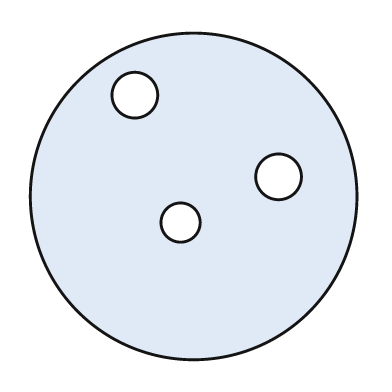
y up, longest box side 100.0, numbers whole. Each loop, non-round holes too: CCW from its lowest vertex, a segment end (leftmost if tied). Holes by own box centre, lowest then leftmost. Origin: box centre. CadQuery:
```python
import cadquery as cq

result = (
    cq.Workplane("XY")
    .moveTo(0.0, 0.0)
    .circle(50.0)
    .moveTo(-4.0, -8.0)
    .circle(6.0)
    .moveTo(26.0, 6.0)
    .circle(7.0)
    .moveTo(-18.0, 31.0)
    .circle(7.0)
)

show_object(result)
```